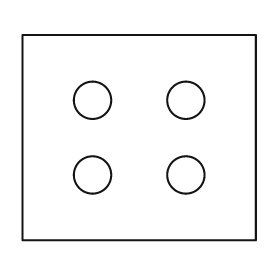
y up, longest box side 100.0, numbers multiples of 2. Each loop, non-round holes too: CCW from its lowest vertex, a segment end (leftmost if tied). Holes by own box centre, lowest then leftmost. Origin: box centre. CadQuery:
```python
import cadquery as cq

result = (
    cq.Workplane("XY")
    .moveTo(-50.0, -44.0)
    .lineTo(50.0, -44.0)
    .lineTo(50.0, 44.0)
    .lineTo(-50.0, 44.0)
    .close()
    .moveTo(-20.0, -16.0)
    .circle(8.0)
    .moveTo(20.0, -16.0)
    .circle(8.0)
    .moveTo(-20.0, 16.0)
    .circle(8.0)
    .moveTo(20.0, 16.0)
    .circle(8.0)
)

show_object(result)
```